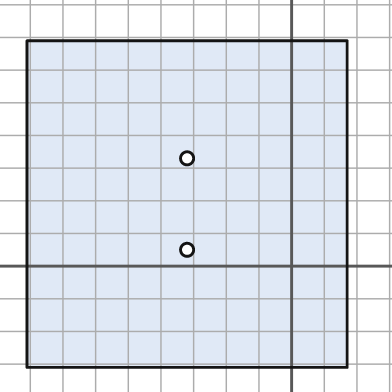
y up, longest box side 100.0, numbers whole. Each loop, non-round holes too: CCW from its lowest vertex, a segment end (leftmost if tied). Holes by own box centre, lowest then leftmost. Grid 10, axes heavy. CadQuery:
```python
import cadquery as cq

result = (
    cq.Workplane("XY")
    .moveTo(-81.0, -31.0)
    .lineTo(17.0, -31.0)
    .lineTo(17.0, 69.0)
    .lineTo(-81.0, 69.0)
    .close()
    .moveTo(-32.0, 5.0)
    .circle(2.0)
    .moveTo(-32.0, 33.0)
    .circle(2.0)
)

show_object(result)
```